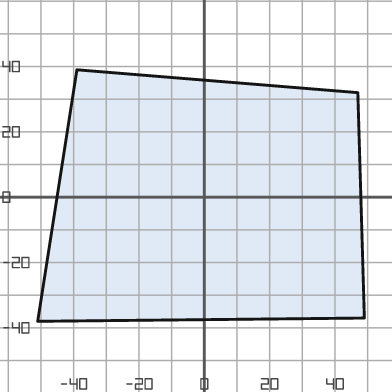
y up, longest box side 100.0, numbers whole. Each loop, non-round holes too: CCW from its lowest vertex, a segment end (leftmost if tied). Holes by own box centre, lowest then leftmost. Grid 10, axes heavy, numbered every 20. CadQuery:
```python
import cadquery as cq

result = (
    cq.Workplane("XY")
    .moveTo(-51.0, -38.0)
    .lineTo(49.0, -37.0)
    .lineTo(47.0, 32.0)
    .lineTo(-39.0, 39.0)
    .close()
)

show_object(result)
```